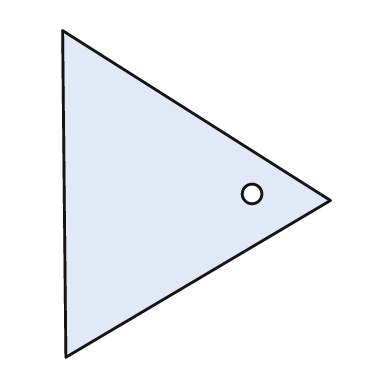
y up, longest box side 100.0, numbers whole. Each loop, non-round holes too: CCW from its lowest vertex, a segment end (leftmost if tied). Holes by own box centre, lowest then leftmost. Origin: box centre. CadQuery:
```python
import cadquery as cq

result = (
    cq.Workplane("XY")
    .moveTo(-40.0, -50.0)
    .lineTo(41.0, -2.0)
    .lineTo(-41.0, 50.0)
    .close()
    .moveTo(17.0, 0.0)
    .circle(3.0)
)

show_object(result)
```